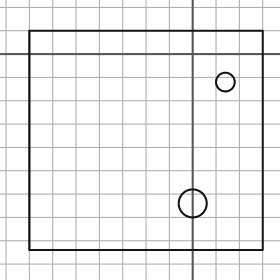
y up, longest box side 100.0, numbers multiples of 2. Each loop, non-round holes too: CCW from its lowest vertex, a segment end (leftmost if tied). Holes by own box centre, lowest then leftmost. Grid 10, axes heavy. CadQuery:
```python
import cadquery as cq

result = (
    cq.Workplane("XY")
    .moveTo(-70.0, -84.0)
    .lineTo(30.0, -84.0)
    .lineTo(30.0, 10.0)
    .lineTo(-70.0, 10.0)
    .close()
    .moveTo(0.0, -64.0)
    .circle(6.0)
    .moveTo(14.0, -12.0)
    .circle(4.0)
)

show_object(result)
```